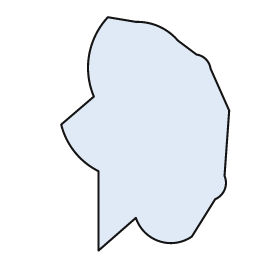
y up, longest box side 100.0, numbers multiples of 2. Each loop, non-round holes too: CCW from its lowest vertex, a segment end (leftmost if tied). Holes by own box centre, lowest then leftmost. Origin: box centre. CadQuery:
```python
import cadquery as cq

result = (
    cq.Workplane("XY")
    .moveTo(-20.0, -50.0)
    .lineTo(-4.0, -36.0)
    .threePointArc((6.0, -46.0), (20.0, -44.0))
    .lineTo(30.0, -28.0)
    .threePointArc((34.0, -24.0), (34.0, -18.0))
    .lineTo(36.0, 10.0)
    .lineTo(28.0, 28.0)
    .threePointArc((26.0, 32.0), (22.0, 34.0))
    .lineTo(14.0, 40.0)
    .threePointArc((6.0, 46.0), (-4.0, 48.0))
    .lineTo(-16.0, 50.0)
    .threePointArc((-24.0, 34.0), (-22.0, 16.0))
    .lineTo(-36.0, 4.0)
    .threePointArc((-30.0, -8.0), (-20.0, -16.0))
    .close()
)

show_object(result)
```